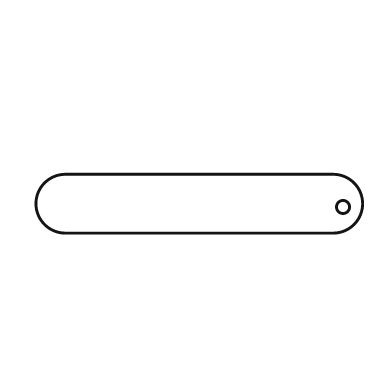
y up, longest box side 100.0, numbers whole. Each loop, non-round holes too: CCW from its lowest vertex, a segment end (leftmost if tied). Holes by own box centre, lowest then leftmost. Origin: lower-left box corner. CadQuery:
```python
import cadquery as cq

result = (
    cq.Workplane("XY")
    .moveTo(9.0, 0.0)
    .lineTo(91.0, 0.0)
    .threePointArc((100.0, 9.0), (91.0, 18.0))
    .lineTo(9.0, 18.0)
    .threePointArc((0.0, 9.0), (9.0, 0.0))
    .close()
    .moveTo(94.0, 8.0)
    .circle(2.0)
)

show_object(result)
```